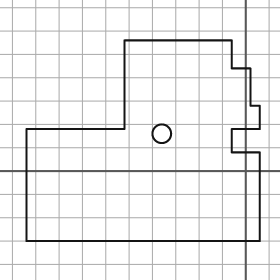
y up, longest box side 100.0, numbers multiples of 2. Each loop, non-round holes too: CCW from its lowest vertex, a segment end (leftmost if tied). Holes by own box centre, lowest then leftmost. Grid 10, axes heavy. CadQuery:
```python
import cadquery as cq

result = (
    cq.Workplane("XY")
    .moveTo(-94.0, -30.0)
    .lineTo(6.0, -30.0)
    .lineTo(6.0, 8.0)
    .lineTo(-6.0, 8.0)
    .lineTo(-6.0, 18.0)
    .lineTo(6.0, 18.0)
    .lineTo(6.0, 28.0)
    .lineTo(2.0, 28.0)
    .lineTo(2.0, 44.0)
    .lineTo(-6.0, 44.0)
    .lineTo(-6.0, 56.0)
    .lineTo(-52.0, 56.0)
    .lineTo(-52.0, 18.0)
    .lineTo(-94.0, 18.0)
    .close()
    .moveTo(-36.0, 16.0)
    .circle(4.0)
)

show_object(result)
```